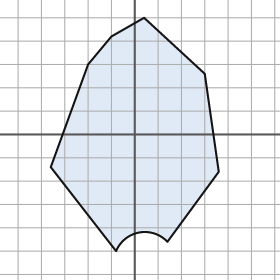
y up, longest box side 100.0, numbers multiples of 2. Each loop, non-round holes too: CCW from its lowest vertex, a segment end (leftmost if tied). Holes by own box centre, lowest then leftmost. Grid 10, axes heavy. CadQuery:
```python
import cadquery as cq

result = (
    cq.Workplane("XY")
    .moveTo(-8.0, -50.0)
    .threePointArc((2.0, -42.0), (14.0, -46.0))
    .lineTo(36.0, -16.0)
    .lineTo(30.0, 26.0)
    .lineTo(4.0, 50.0)
    .lineTo(-10.0, 42.0)
    .lineTo(-20.0, 30.0)
    .lineTo(-36.0, -14.0)
    .close()
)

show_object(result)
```